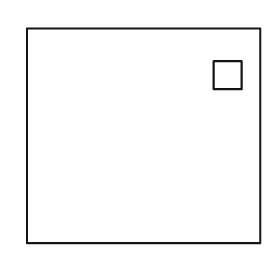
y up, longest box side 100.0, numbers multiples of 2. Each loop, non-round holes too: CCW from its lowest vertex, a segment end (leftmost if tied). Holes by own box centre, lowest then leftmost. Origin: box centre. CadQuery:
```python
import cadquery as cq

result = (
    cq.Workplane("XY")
    .moveTo(-50.0, -46.0)
    .lineTo(50.0, -46.0)
    .lineTo(50.0, 46.0)
    .lineTo(-50.0, 46.0)
    .close()
    .moveTo(30.0, 20.0)
    .lineTo(42.0, 20.0)
    .lineTo(42.0, 32.0)
    .lineTo(30.0, 32.0)
    .close()
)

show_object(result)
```